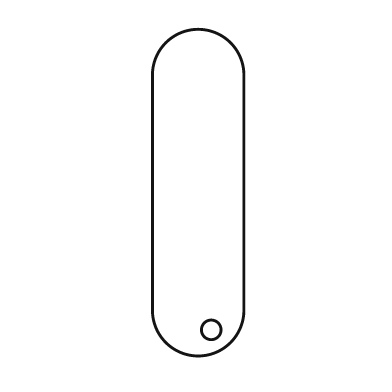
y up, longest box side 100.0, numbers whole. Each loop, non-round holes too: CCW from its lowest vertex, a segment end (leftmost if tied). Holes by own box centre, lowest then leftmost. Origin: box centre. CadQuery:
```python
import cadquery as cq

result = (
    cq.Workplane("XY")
    .moveTo(-14.0, -36.0)
    .threePointArc((0.0, -50.0), (14.0, -36.0))
    .lineTo(14.0, 36.0)
    .threePointArc((0.0, 50.0), (-14.0, 36.0))
    .close()
    .moveTo(4.0, -42.0)
    .circle(3.0)
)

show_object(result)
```